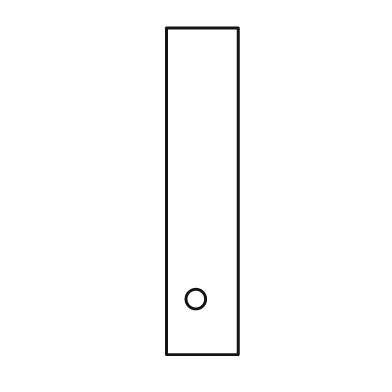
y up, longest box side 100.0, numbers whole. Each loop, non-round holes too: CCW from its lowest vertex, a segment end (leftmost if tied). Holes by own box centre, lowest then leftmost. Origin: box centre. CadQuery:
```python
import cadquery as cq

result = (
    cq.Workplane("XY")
    .moveTo(-11.0, -50.0)
    .lineTo(11.0, -50.0)
    .lineTo(11.0, 50.0)
    .lineTo(-11.0, 50.0)
    .close()
    .moveTo(-2.0, -33.0)
    .circle(3.0)
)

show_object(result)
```